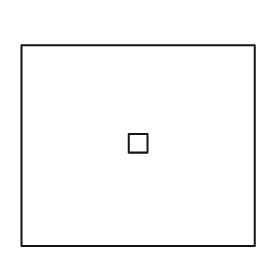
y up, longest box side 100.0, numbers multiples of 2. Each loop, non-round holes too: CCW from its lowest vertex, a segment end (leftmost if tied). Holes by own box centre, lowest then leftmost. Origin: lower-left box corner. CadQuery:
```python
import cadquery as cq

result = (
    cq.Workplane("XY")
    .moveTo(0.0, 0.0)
    .lineTo(100.0, 0.0)
    .lineTo(100.0, 86.0)
    .lineTo(0.0, 86.0)
    .close()
    .moveTo(46.0, 40.0)
    .lineTo(54.0, 40.0)
    .lineTo(54.0, 48.0)
    .lineTo(46.0, 48.0)
    .close()
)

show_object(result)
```